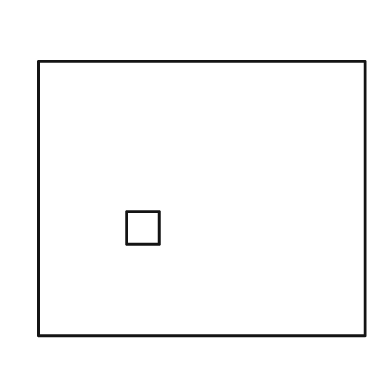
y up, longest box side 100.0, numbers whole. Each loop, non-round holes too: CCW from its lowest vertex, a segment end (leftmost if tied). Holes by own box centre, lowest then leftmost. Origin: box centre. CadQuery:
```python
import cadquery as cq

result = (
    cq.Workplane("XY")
    .moveTo(-50.0, -42.0)
    .lineTo(50.0, -42.0)
    .lineTo(50.0, 42.0)
    .lineTo(-50.0, 42.0)
    .close()
    .moveTo(-23.0, -14.0)
    .lineTo(-13.0, -14.0)
    .lineTo(-13.0, -4.0)
    .lineTo(-23.0, -4.0)
    .close()
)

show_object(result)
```